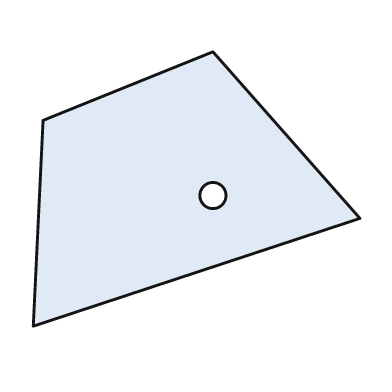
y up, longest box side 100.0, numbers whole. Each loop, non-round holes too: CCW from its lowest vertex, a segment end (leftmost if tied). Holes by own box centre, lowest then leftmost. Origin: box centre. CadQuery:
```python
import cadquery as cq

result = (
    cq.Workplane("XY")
    .moveTo(-50.0, -42.0)
    .lineTo(50.0, -9.0)
    .lineTo(5.0, 42.0)
    .lineTo(-47.0, 21.0)
    .close()
    .moveTo(5.0, -2.0)
    .circle(4.0)
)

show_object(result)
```